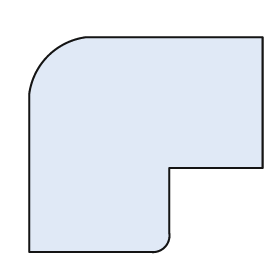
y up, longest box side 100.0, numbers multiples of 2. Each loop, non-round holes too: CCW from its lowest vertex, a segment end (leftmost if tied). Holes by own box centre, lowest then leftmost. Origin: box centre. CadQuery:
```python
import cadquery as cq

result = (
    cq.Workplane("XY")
    .moveTo(-50.0, -46.0)
    .lineTo(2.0, -46.0)
    .threePointArc((8.0, -44.0), (10.0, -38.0))
    .lineTo(10.0, -10.0)
    .lineTo(50.0, -10.0)
    .lineTo(50.0, 46.0)
    .lineTo(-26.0, 46.0)
    .threePointArc((-42.0, 38.0), (-50.0, 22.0))
    .close()
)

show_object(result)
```